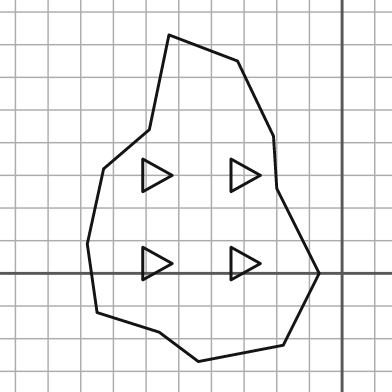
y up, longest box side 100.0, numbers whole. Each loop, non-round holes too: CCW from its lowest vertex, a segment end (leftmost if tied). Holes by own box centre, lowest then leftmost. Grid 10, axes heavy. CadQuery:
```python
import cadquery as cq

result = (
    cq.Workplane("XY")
    .moveTo(-44.0, -27.0)
    .lineTo(-18.0, -22.0)
    .lineTo(-7.0, 0.0)
    .lineTo(-20.0, 26.0)
    .lineTo(-21.0, 42.0)
    .lineTo(-32.0, 65.0)
    .lineTo(-53.0, 73.0)
    .lineTo(-59.0, 44.0)
    .lineTo(-73.0, 32.0)
    .lineTo(-78.0, 9.0)
    .lineTo(-75.0, -12.0)
    .lineTo(-56.0, -18.0)
    .close()
    .moveTo(-61.0, -2.0)
    .lineTo(-52.0, 3.0)
    .lineTo(-61.0, 8.0)
    .close()
    .moveTo(-34.0, -2.0)
    .lineTo(-25.0, 3.0)
    .lineTo(-34.0, 8.0)
    .close()
    .moveTo(-61.0, 25.0)
    .lineTo(-52.0, 30.0)
    .lineTo(-61.0, 35.0)
    .close()
    .moveTo(-34.0, 25.0)
    .lineTo(-25.0, 30.0)
    .lineTo(-34.0, 35.0)
    .close()
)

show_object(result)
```